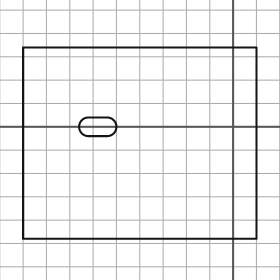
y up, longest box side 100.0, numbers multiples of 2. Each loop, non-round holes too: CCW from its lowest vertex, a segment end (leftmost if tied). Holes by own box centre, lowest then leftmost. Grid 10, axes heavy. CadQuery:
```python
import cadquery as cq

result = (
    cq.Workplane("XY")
    .moveTo(-90.0, -48.0)
    .lineTo(10.0, -48.0)
    .lineTo(10.0, 34.0)
    .lineTo(-90.0, 34.0)
    .close()
    .moveTo(-62.0, -4.0)
    .lineTo(-54.0, -4.0)
    .threePointArc((-50.0, 0.0), (-54.0, 4.0))
    .lineTo(-62.0, 4.0)
    .threePointArc((-66.0, 0.0), (-62.0, -4.0))
    .close()
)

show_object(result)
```